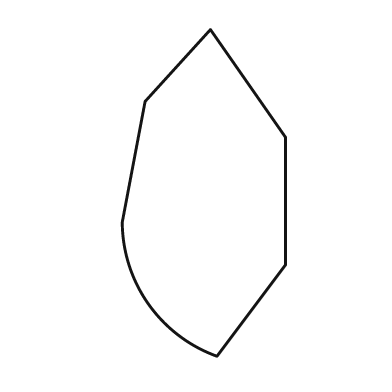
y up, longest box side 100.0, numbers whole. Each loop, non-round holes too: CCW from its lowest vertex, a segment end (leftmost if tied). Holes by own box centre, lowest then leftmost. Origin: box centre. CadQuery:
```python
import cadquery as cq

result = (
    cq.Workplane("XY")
    .moveTo(4.0, -50.0)
    .lineTo(25.0, -22.0)
    .lineTo(25.0, 17.0)
    .lineTo(2.0, 50.0)
    .lineTo(-18.0, 28.0)
    .lineTo(-25.0, -9.0)
    .threePointArc((-17.0, -34.0), (4.0, -50.0))
    .close()
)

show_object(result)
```